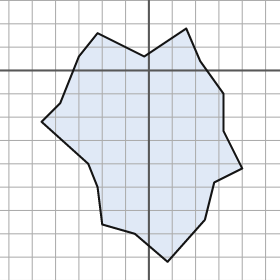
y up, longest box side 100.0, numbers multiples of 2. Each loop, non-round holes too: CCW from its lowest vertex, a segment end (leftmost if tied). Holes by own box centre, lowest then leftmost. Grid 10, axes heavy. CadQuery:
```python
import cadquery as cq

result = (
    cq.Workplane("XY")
    .moveTo(8.0, -82.0)
    .lineTo(24.0, -64.0)
    .lineTo(28.0, -48.0)
    .lineTo(40.0, -42.0)
    .lineTo(32.0, -26.0)
    .lineTo(32.0, -10.0)
    .lineTo(22.0, 4.0)
    .lineTo(16.0, 18.0)
    .lineTo(-2.0, 6.0)
    .lineTo(-22.0, 16.0)
    .lineTo(-30.0, 6.0)
    .lineTo(-38.0, -14.0)
    .lineTo(-46.0, -22.0)
    .lineTo(-26.0, -40.0)
    .lineTo(-22.0, -50.0)
    .lineTo(-20.0, -66.0)
    .lineTo(-6.0, -70.0)
    .close()
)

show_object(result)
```